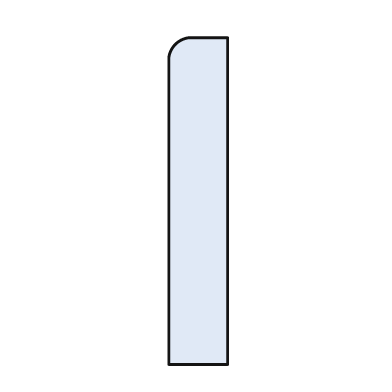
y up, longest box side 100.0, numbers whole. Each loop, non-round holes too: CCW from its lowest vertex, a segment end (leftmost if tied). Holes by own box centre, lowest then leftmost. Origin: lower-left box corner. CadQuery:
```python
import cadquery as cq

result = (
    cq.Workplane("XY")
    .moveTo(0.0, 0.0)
    .lineTo(18.0, 0.0)
    .lineTo(18.0, 100.0)
    .lineTo(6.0, 100.0)
    .threePointArc((2.0, 98.0), (0.0, 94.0))
    .close()
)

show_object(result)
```